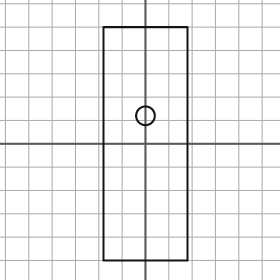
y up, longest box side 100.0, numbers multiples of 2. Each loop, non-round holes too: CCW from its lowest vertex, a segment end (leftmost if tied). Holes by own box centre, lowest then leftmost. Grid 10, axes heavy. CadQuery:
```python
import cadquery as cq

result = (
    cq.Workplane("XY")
    .moveTo(-18.0, -50.0)
    .lineTo(18.0, -50.0)
    .lineTo(18.0, 50.0)
    .lineTo(-18.0, 50.0)
    .close()
    .moveTo(0.0, 12.0)
    .circle(4.0)
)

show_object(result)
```